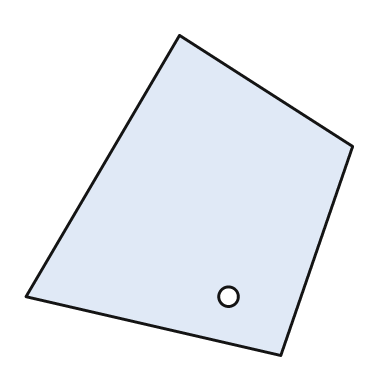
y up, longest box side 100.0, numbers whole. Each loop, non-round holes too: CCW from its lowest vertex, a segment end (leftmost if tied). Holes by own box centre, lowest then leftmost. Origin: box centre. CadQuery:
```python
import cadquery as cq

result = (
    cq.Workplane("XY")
    .moveTo(28.0, -49.0)
    .lineTo(50.0, 15.0)
    .lineTo(-3.0, 49.0)
    .lineTo(-50.0, -31.0)
    .close()
    .moveTo(12.0, -31.0)
    .circle(3.0)
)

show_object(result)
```